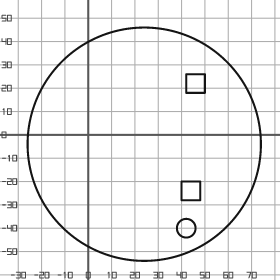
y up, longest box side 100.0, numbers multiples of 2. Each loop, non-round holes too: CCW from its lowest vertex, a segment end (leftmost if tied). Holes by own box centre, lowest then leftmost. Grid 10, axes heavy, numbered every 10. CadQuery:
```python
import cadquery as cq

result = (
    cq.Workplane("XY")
    .moveTo(24.0, -4.0)
    .circle(50.0)
    .moveTo(42.0, -40.0)
    .circle(4.0)
    .moveTo(40.0, -28.0)
    .lineTo(48.0, -28.0)
    .lineTo(48.0, -20.0)
    .lineTo(40.0, -20.0)
    .close()
    .moveTo(42.0, 18.0)
    .lineTo(50.0, 18.0)
    .lineTo(50.0, 26.0)
    .lineTo(42.0, 26.0)
    .close()
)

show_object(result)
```